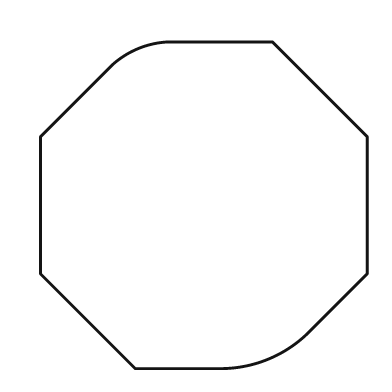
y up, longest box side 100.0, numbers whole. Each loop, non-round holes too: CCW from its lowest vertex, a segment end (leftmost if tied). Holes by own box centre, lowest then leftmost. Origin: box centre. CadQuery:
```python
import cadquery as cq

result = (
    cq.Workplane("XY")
    .moveTo(-21.0, -50.0)
    .lineTo(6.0, -50.0)
    .threePointArc((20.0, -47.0), (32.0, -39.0))
    .lineTo(50.0, -21.0)
    .lineTo(50.0, 21.0)
    .lineTo(21.0, 50.0)
    .lineTo(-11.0, 50.0)
    .threePointArc((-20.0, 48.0), (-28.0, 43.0))
    .lineTo(-50.0, 21.0)
    .lineTo(-50.0, -21.0)
    .close()
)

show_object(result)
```